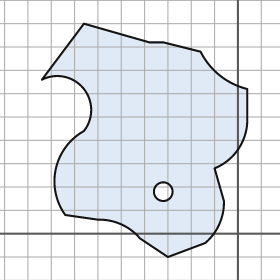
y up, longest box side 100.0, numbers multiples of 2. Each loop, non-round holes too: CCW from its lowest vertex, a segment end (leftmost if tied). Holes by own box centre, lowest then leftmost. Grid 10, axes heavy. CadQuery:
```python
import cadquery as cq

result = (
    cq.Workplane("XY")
    .moveTo(-30.0, -10.0)
    .lineTo(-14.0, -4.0)
    .threePointArc((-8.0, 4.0), (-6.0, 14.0))
    .lineTo(-10.0, 28.0)
    .threePointArc((0.0, 36.0), (4.0, 48.0))
    .lineTo(4.0, 62.0)
    .threePointArc((-8.0, 68.0), (-16.0, 78.0))
    .lineTo(-32.0, 82.0)
    .lineTo(-38.0, 82.0)
    .lineTo(-66.0, 90.0)
    .lineTo(-84.0, 66.0)
    .threePointArc((-66.0, 62.0), (-66.0, 44.0))
    .threePointArc((-78.0, 28.0), (-74.0, 8.0))
    .lineTo(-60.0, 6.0)
    .threePointArc((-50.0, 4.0), (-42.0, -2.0))
    .close()
    .moveTo(-32.0, 18.0)
    .circle(4.0)
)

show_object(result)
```